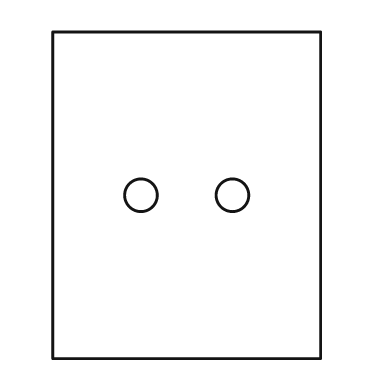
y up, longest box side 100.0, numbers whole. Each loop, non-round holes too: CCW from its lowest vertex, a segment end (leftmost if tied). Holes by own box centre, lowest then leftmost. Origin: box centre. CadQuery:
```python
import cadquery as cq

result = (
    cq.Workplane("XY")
    .moveTo(-41.0, -50.0)
    .lineTo(41.0, -50.0)
    .lineTo(41.0, 50.0)
    .lineTo(-41.0, 50.0)
    .close()
    .moveTo(-14.0, 0.0)
    .circle(5.0)
    .moveTo(14.0, 0.0)
    .circle(5.0)
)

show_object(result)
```